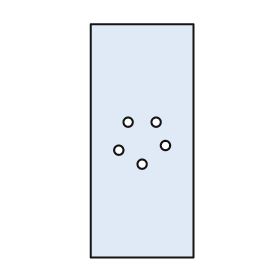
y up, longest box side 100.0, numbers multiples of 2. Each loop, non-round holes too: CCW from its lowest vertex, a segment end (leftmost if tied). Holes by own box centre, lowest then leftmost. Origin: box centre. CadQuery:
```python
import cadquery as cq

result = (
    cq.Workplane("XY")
    .moveTo(-22.0, -50.0)
    .lineTo(22.0, -50.0)
    .lineTo(22.0, 50.0)
    .lineTo(-22.0, 50.0)
    .close()
    .moveTo(0.0, -10.0)
    .circle(2.0)
    .moveTo(-10.0, -4.0)
    .circle(2.0)
    .moveTo(10.0, -2.0)
    .circle(2.0)
    .moveTo(-6.0, 8.0)
    .circle(2.0)
    .moveTo(6.0, 8.0)
    .circle(2.0)
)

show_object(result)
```